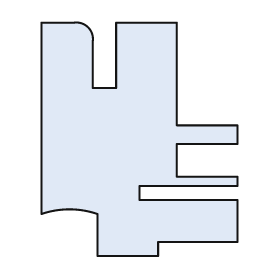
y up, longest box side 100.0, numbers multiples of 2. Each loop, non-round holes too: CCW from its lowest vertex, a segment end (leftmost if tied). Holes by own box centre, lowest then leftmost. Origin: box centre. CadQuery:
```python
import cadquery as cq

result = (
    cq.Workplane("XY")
    .moveTo(-18.0, -50.0)
    .lineTo(8.0, -50.0)
    .lineTo(8.0, -44.0)
    .lineTo(42.0, -44.0)
    .lineTo(42.0, -26.0)
    .lineTo(0.0, -26.0)
    .lineTo(0.0, -20.0)
    .lineTo(42.0, -20.0)
    .lineTo(42.0, -16.0)
    .lineTo(16.0, -16.0)
    .lineTo(16.0, -2.0)
    .lineTo(42.0, -2.0)
    .lineTo(42.0, 6.0)
    .lineTo(16.0, 6.0)
    .lineTo(16.0, 50.0)
    .lineTo(-10.0, 50.0)
    .lineTo(-10.0, 22.0)
    .lineTo(-20.0, 22.0)
    .lineTo(-20.0, 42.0)
    .threePointArc((-22.0, 48.0), (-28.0, 50.0))
    .lineTo(-42.0, 50.0)
    .lineTo(-42.0, -32.0)
    .threePointArc((-30.0, -30.0), (-18.0, -32.0))
    .close()
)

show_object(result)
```